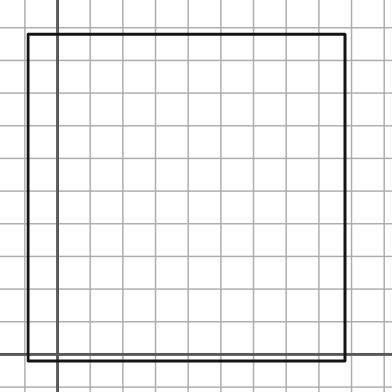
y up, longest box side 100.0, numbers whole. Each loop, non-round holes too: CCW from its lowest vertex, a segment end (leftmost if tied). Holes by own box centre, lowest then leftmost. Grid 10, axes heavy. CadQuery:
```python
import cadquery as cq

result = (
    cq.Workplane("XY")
    .moveTo(-9.0, -2.0)
    .lineTo(88.0, -2.0)
    .lineTo(88.0, 98.0)
    .lineTo(-9.0, 98.0)
    .close()
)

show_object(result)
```